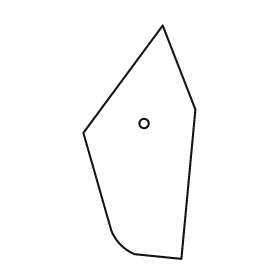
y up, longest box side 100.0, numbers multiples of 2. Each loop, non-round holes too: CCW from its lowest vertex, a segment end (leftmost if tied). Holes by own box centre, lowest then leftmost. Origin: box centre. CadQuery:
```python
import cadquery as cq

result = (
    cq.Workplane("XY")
    .moveTo(18.0, -50.0)
    .lineTo(24.0, 14.0)
    .lineTo(10.0, 50.0)
    .lineTo(-24.0, 4.0)
    .lineTo(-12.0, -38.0)
    .threePointArc((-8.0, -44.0), (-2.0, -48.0))
    .close()
    .moveTo(2.0, 8.0)
    .circle(2.0)
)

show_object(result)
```